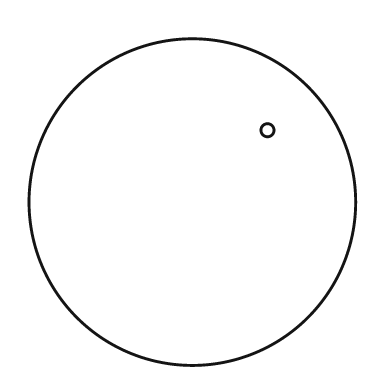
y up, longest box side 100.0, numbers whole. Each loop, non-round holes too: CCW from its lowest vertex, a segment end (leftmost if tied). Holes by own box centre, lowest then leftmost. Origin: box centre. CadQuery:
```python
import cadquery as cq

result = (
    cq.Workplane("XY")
    .moveTo(0.0, 0.0)
    .circle(50.0)
    .moveTo(23.0, 22.0)
    .circle(2.0)
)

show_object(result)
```